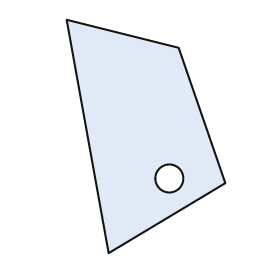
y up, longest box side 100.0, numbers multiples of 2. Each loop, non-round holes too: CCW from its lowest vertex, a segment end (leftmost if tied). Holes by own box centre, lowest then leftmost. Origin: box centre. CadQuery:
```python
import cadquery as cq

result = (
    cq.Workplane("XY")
    .moveTo(-16.0, -50.0)
    .lineTo(34.0, -20.0)
    .lineTo(14.0, 38.0)
    .lineTo(-34.0, 50.0)
    .close()
    .moveTo(10.0, -18.0)
    .circle(6.0)
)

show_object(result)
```